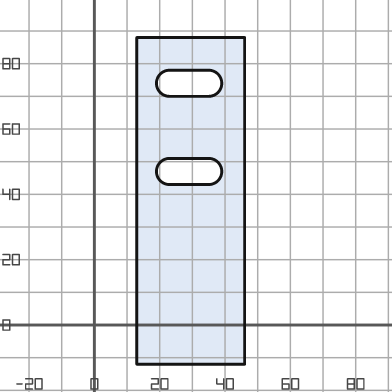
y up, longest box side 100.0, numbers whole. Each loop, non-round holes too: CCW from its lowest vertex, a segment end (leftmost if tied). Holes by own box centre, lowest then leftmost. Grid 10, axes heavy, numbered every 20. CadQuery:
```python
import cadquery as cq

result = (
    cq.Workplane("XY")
    .moveTo(13.0, -12.0)
    .lineTo(46.0, -12.0)
    .lineTo(46.0, 88.0)
    .lineTo(13.0, 88.0)
    .close()
    .moveTo(23.0, 43.0)
    .lineTo(35.0, 43.0)
    .threePointArc((39.0, 47.0), (35.0, 51.0))
    .lineTo(23.0, 51.0)
    .threePointArc((19.0, 47.0), (23.0, 43.0))
    .close()
    .moveTo(23.0, 70.0)
    .lineTo(35.0, 70.0)
    .threePointArc((39.0, 74.0), (35.0, 78.0))
    .lineTo(23.0, 78.0)
    .threePointArc((19.0, 74.0), (23.0, 70.0))
    .close()
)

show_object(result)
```